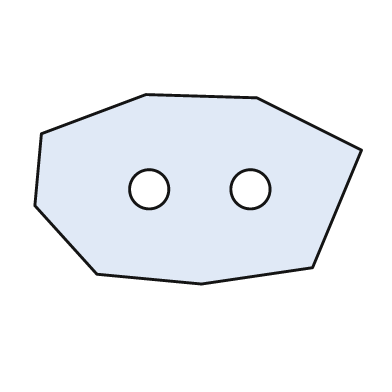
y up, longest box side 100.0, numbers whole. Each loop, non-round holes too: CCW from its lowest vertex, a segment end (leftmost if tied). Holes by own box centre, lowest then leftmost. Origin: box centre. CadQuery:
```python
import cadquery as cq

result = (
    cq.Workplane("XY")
    .moveTo(1.0, -29.0)
    .lineTo(35.0, -24.0)
    .lineTo(50.0, 12.0)
    .lineTo(18.0, 28.0)
    .lineTo(-16.0, 29.0)
    .lineTo(-48.0, 17.0)
    .lineTo(-50.0, -5.0)
    .lineTo(-31.0, -26.0)
    .close()
    .moveTo(-15.0, 0.0)
    .circle(6.0)
    .moveTo(16.0, 0.0)
    .circle(6.0)
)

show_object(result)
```